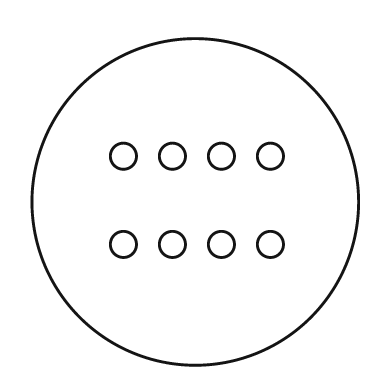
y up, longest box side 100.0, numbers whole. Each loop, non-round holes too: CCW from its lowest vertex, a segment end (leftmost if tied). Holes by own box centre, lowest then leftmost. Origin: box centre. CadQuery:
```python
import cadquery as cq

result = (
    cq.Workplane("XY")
    .moveTo(0.0, 0.0)
    .circle(50.0)
    .moveTo(-22.0, -13.0)
    .circle(4.0)
    .moveTo(-7.0, -13.0)
    .circle(4.0)
    .moveTo(8.0, -13.0)
    .circle(4.0)
    .moveTo(23.0, -13.0)
    .circle(4.0)
    .moveTo(-22.0, 14.0)
    .circle(4.0)
    .moveTo(-7.0, 14.0)
    .circle(4.0)
    .moveTo(8.0, 14.0)
    .circle(4.0)
    .moveTo(23.0, 14.0)
    .circle(4.0)
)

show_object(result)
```